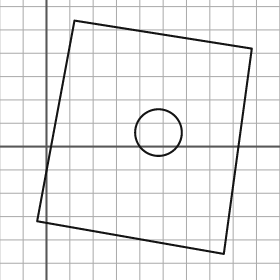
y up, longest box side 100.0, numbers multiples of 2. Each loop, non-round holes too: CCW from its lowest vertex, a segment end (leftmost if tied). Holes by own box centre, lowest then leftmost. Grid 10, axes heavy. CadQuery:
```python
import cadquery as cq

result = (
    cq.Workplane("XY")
    .moveTo(76.0, -46.0)
    .lineTo(88.0, 42.0)
    .lineTo(12.0, 54.0)
    .lineTo(-4.0, -32.0)
    .close()
    .moveTo(48.0, 6.0)
    .circle(10.0)
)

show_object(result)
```